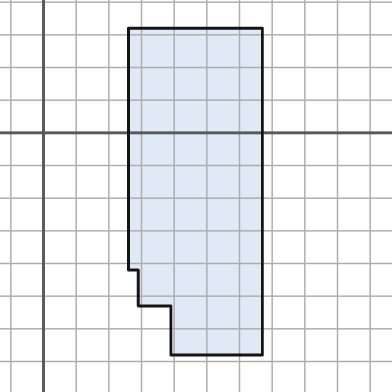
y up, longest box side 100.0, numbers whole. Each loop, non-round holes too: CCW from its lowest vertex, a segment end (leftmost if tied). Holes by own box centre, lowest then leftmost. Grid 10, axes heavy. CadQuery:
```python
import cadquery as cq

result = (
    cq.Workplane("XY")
    .moveTo(39.0, -68.0)
    .lineTo(67.0, -68.0)
    .lineTo(67.0, 32.0)
    .lineTo(26.0, 32.0)
    .lineTo(26.0, -42.0)
    .lineTo(29.0, -42.0)
    .lineTo(29.0, -53.0)
    .lineTo(39.0, -53.0)
    .close()
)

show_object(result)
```